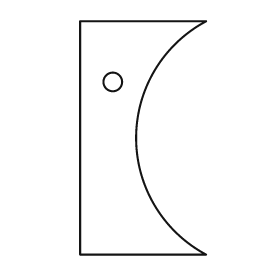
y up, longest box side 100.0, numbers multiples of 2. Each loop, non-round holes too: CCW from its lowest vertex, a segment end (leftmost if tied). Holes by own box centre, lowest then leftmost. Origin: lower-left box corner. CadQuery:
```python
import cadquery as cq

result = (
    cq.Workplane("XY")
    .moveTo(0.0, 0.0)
    .lineTo(54.0, 0.0)
    .threePointArc((24.0, 50.0), (54.0, 100.0))
    .lineTo(0.0, 100.0)
    .close()
    .moveTo(14.0, 74.0)
    .circle(4.0)
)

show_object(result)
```